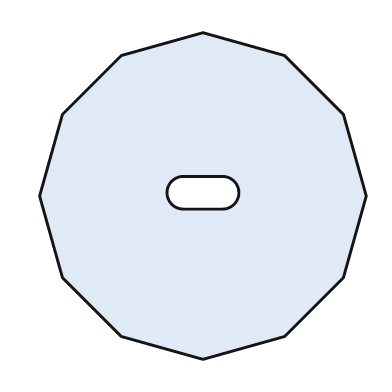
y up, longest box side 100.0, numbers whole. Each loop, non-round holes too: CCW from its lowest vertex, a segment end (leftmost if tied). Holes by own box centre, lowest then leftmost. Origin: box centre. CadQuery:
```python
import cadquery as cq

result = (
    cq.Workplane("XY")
    .moveTo(0.0, -50.0)
    .lineTo(25.0, -43.0)
    .lineTo(43.0, -25.0)
    .lineTo(50.0, 0.0)
    .lineTo(43.0, 25.0)
    .lineTo(25.0, 43.0)
    .lineTo(0.0, 50.0)
    .lineTo(-25.0, 43.0)
    .lineTo(-43.0, 25.0)
    .lineTo(-50.0, 0.0)
    .lineTo(-43.0, -25.0)
    .lineTo(-25.0, -43.0)
    .close()
    .moveTo(-6.0, -4.0)
    .lineTo(6.0, -4.0)
    .threePointArc((11.0, 1.0), (6.0, 6.0))
    .lineTo(-6.0, 6.0)
    .threePointArc((-11.0, 1.0), (-6.0, -4.0))
    .close()
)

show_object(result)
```